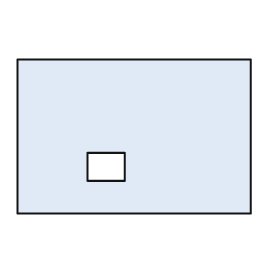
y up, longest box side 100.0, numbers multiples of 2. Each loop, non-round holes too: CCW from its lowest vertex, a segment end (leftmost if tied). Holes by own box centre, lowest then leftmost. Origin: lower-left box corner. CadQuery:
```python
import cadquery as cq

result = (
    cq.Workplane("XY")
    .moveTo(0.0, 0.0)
    .lineTo(100.0, 0.0)
    .lineTo(100.0, 66.0)
    .lineTo(0.0, 66.0)
    .close()
    .moveTo(30.0, 14.0)
    .lineTo(46.0, 14.0)
    .lineTo(46.0, 26.0)
    .lineTo(30.0, 26.0)
    .close()
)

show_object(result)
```